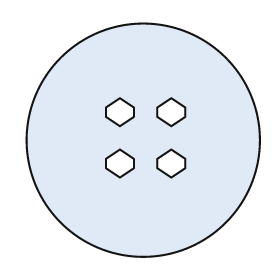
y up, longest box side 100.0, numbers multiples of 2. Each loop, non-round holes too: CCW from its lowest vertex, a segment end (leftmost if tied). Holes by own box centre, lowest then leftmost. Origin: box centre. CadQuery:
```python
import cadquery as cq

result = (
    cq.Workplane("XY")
    .moveTo(0.0, 0.0)
    .circle(50.0)
    .moveTo(-10.0, -16.0)
    .lineTo(-4.0, -12.0)
    .lineTo(-4.0, -8.0)
    .lineTo(-10.0, -4.0)
    .lineTo(-16.0, -8.0)
    .lineTo(-16.0, -12.0)
    .close()
    .moveTo(12.0, -16.0)
    .lineTo(18.0, -12.0)
    .lineTo(18.0, -8.0)
    .lineTo(12.0, -4.0)
    .lineTo(6.0, -8.0)
    .lineTo(6.0, -12.0)
    .close()
    .moveTo(-10.0, 6.0)
    .lineTo(-4.0, 10.0)
    .lineTo(-4.0, 14.0)
    .lineTo(-10.0, 18.0)
    .lineTo(-16.0, 14.0)
    .lineTo(-16.0, 10.0)
    .close()
    .moveTo(12.0, 6.0)
    .lineTo(18.0, 10.0)
    .lineTo(18.0, 14.0)
    .lineTo(12.0, 18.0)
    .lineTo(6.0, 14.0)
    .lineTo(6.0, 10.0)
    .close()
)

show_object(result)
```